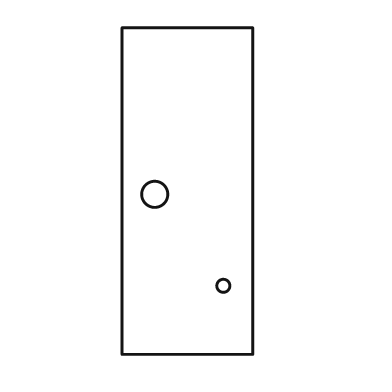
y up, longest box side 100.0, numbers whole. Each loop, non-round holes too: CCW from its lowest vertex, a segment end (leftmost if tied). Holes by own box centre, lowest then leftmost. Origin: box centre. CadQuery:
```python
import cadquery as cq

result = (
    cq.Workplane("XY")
    .moveTo(-20.0, -50.0)
    .lineTo(20.0, -50.0)
    .lineTo(20.0, 50.0)
    .lineTo(-20.0, 50.0)
    .close()
    .moveTo(11.0, -29.0)
    .circle(2.0)
    .moveTo(-10.0, -1.0)
    .circle(4.0)
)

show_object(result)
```